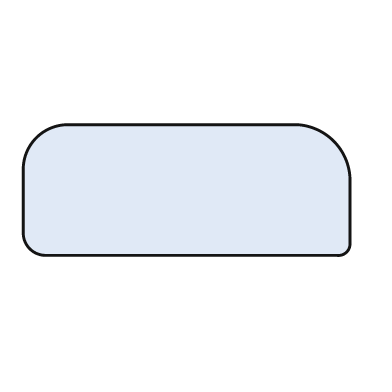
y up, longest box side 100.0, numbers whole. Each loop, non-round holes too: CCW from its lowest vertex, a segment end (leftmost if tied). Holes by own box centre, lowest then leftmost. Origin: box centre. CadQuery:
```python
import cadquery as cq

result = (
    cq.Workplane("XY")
    .moveTo(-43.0, -20.0)
    .lineTo(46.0, -20.0)
    .threePointArc((49.0, -19.0), (50.0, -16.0))
    .lineTo(50.0, 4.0)
    .threePointArc((45.0, 15.0), (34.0, 20.0))
    .lineTo(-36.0, 20.0)
    .threePointArc((-46.0, 16.0), (-50.0, 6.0))
    .lineTo(-50.0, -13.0)
    .threePointArc((-48.0, -18.0), (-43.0, -20.0))
    .close()
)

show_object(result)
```